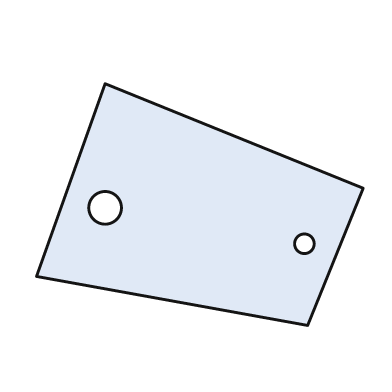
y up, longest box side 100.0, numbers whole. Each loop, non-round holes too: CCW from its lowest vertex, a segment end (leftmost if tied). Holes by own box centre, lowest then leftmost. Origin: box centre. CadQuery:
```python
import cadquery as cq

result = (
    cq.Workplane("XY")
    .moveTo(33.0, -37.0)
    .lineTo(50.0, 5.0)
    .lineTo(-29.0, 37.0)
    .lineTo(-50.0, -22.0)
    .close()
    .moveTo(32.0, -12.0)
    .circle(3.0)
    .moveTo(-29.0, -1.0)
    .circle(5.0)
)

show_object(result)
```